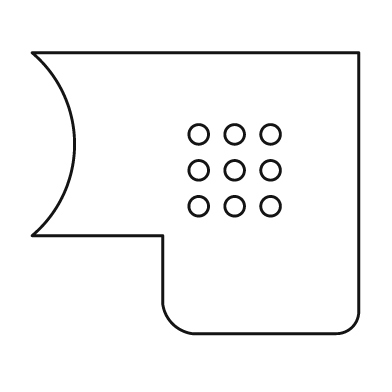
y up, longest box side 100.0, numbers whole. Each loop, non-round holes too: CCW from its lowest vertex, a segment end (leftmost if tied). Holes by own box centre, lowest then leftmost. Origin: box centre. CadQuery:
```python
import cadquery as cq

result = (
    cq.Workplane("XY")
    .moveTo(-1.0, -43.0)
    .lineTo(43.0, -43.0)
    .threePointArc((48.0, -41.0), (50.0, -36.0))
    .lineTo(50.0, 43.0)
    .lineTo(-50.0, 43.0)
    .threePointArc((-37.0, 15.0), (-50.0, -13.0))
    .lineTo(-10.0, -13.0)
    .lineTo(-10.0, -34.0)
    .threePointArc((-7.0, -40.0), (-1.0, -43.0))
    .close()
    .moveTo(1.0, -4.0)
    .circle(3.0)
    .moveTo(12.0, -4.0)
    .circle(3.0)
    .moveTo(23.0, -4.0)
    .circle(3.0)
    .moveTo(1.0, 7.0)
    .circle(3.0)
    .moveTo(12.0, 7.0)
    .circle(3.0)
    .moveTo(23.0, 7.0)
    .circle(3.0)
    .moveTo(1.0, 18.0)
    .circle(3.0)
    .moveTo(12.0, 18.0)
    .circle(3.0)
    .moveTo(23.0, 18.0)
    .circle(3.0)
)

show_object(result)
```